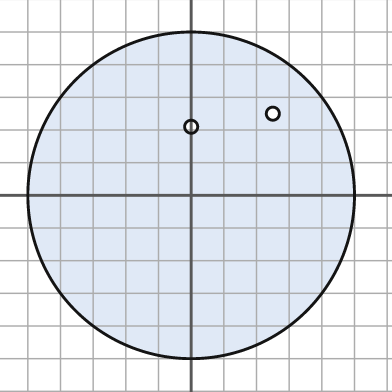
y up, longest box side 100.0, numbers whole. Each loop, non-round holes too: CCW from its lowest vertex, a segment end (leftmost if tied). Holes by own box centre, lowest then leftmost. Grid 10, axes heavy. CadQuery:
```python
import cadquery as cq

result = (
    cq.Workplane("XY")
    .moveTo(0.0, 0.0)
    .circle(50.0)
    .moveTo(0.0, 21.0)
    .circle(2.0)
    .moveTo(25.0, 25.0)
    .circle(2.0)
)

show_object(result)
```